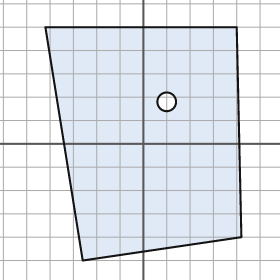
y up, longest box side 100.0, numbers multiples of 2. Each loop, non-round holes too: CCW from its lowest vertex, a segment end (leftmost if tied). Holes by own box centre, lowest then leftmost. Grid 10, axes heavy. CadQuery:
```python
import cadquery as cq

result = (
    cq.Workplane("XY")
    .moveTo(-26.0, -50.0)
    .lineTo(42.0, -40.0)
    .lineTo(40.0, 50.0)
    .lineTo(-42.0, 50.0)
    .close()
    .moveTo(10.0, 18.0)
    .circle(4.0)
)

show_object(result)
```